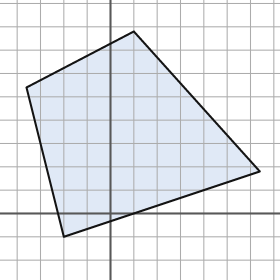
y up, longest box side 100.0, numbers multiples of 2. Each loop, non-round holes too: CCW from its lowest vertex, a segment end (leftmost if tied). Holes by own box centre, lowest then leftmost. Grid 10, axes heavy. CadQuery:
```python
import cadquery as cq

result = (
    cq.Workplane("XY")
    .moveTo(-20.0, -10.0)
    .lineTo(64.0, 18.0)
    .lineTo(10.0, 78.0)
    .lineTo(-36.0, 54.0)
    .close()
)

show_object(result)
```